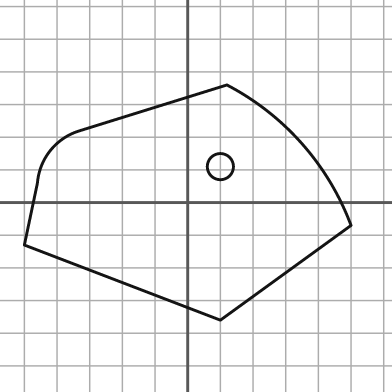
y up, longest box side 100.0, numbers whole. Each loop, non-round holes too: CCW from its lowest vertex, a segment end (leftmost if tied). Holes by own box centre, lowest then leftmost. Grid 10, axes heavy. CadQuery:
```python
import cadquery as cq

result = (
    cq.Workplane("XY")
    .moveTo(10.0, -36.0)
    .lineTo(50.0, -7.0)
    .threePointArc((35.0, 18.0), (12.0, 36.0))
    .lineTo(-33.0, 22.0)
    .threePointArc((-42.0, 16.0), (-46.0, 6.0))
    .lineTo(-50.0, -13.0)
    .close()
    .moveTo(10.0, 11.0)
    .circle(4.0)
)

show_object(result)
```